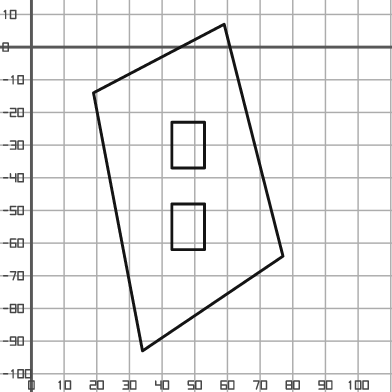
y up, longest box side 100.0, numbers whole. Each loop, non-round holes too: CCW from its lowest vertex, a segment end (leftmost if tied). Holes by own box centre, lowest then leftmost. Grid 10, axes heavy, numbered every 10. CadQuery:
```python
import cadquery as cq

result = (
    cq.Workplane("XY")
    .moveTo(34.0, -93.0)
    .lineTo(77.0, -64.0)
    .lineTo(59.0, 7.0)
    .lineTo(19.0, -14.0)
    .close()
    .moveTo(43.0, -62.0)
    .lineTo(53.0, -62.0)
    .lineTo(53.0, -48.0)
    .lineTo(43.0, -48.0)
    .close()
    .moveTo(43.0, -37.0)
    .lineTo(53.0, -37.0)
    .lineTo(53.0, -23.0)
    .lineTo(43.0, -23.0)
    .close()
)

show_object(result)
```